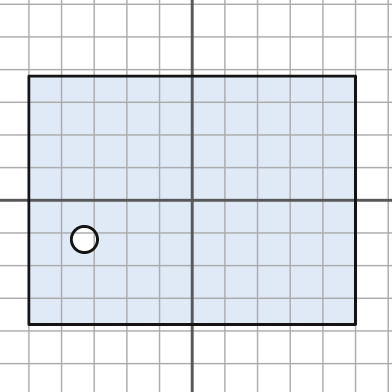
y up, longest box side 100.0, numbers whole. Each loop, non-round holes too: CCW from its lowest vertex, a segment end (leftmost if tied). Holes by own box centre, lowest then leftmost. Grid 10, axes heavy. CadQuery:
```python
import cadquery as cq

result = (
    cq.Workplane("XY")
    .moveTo(-50.0, -38.0)
    .lineTo(50.0, -38.0)
    .lineTo(50.0, 38.0)
    .lineTo(-50.0, 38.0)
    .close()
    .moveTo(-33.0, -12.0)
    .circle(4.0)
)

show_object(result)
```